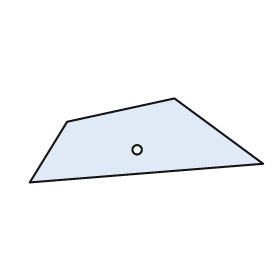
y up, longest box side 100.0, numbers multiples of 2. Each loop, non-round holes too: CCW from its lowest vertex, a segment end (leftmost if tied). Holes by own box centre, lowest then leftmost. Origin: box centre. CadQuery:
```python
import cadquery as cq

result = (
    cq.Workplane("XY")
    .moveTo(-50.0, -18.0)
    .lineTo(50.0, -10.0)
    .lineTo(12.0, 18.0)
    .lineTo(-34.0, 8.0)
    .close()
    .moveTo(-4.0, -4.0)
    .circle(2.0)
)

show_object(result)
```